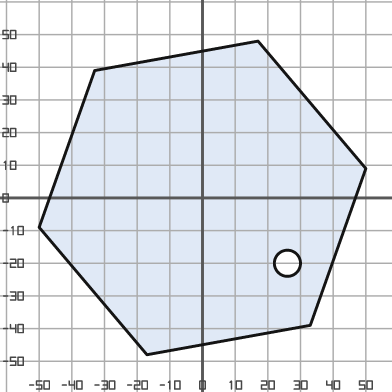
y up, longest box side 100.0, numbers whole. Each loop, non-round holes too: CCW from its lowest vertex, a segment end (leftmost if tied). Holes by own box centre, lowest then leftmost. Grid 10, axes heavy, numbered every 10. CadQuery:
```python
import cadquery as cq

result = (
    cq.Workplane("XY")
    .moveTo(-17.0, -48.0)
    .lineTo(33.0, -39.0)
    .lineTo(50.0, 9.0)
    .lineTo(17.0, 48.0)
    .lineTo(-33.0, 39.0)
    .lineTo(-50.0, -9.0)
    .close()
    .moveTo(26.0, -20.0)
    .circle(4.0)
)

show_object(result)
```